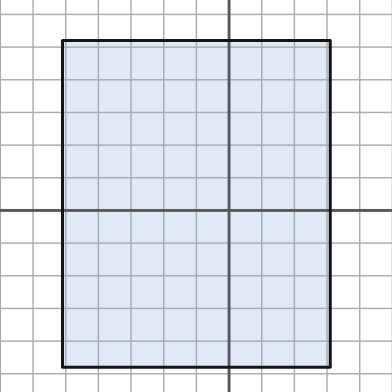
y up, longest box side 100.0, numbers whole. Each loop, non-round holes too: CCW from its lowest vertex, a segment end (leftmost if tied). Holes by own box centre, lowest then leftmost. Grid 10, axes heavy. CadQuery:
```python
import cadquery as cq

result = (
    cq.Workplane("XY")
    .moveTo(-51.0, -48.0)
    .lineTo(31.0, -48.0)
    .lineTo(31.0, 52.0)
    .lineTo(-51.0, 52.0)
    .close()
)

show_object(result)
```